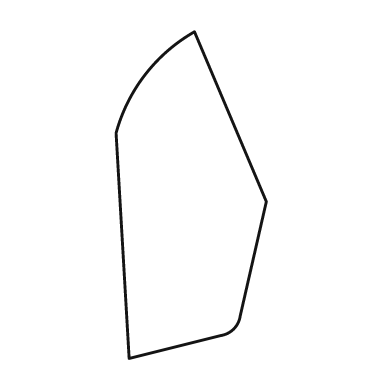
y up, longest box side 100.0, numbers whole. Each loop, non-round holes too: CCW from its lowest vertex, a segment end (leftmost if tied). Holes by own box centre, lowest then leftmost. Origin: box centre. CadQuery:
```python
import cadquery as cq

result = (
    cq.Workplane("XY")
    .moveTo(-19.0, -50.0)
    .lineTo(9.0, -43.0)
    .threePointArc((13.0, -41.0), (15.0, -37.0))
    .lineTo(23.0, -2.0)
    .lineTo(1.0, 50.0)
    .threePointArc((-14.0, 37.0), (-23.0, 19.0))
    .close()
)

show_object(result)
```